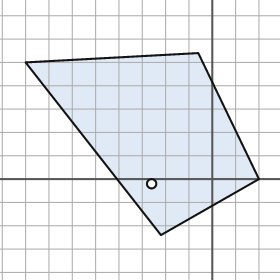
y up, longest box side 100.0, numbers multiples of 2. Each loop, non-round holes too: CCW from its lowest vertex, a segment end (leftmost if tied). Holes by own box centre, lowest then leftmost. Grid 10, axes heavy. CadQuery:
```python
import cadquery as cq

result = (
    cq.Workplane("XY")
    .moveTo(-22.0, -24.0)
    .lineTo(20.0, 0.0)
    .lineTo(-6.0, 54.0)
    .lineTo(-80.0, 50.0)
    .close()
    .moveTo(-26.0, -2.0)
    .circle(2.0)
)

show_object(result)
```